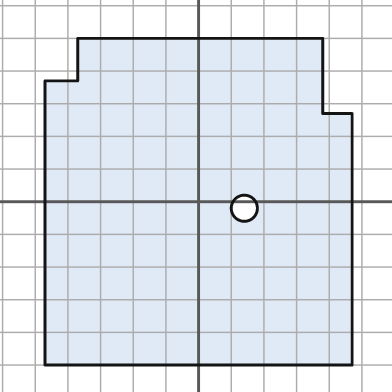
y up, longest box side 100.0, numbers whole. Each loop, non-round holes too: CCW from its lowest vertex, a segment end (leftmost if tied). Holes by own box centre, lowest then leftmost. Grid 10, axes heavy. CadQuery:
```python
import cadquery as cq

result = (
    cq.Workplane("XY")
    .moveTo(-47.0, -50.0)
    .lineTo(47.0, -50.0)
    .lineTo(47.0, 27.0)
    .lineTo(38.0, 27.0)
    .lineTo(38.0, 50.0)
    .lineTo(-37.0, 50.0)
    .lineTo(-37.0, 37.0)
    .lineTo(-47.0, 37.0)
    .close()
    .moveTo(14.0, -2.0)
    .circle(4.0)
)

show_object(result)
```